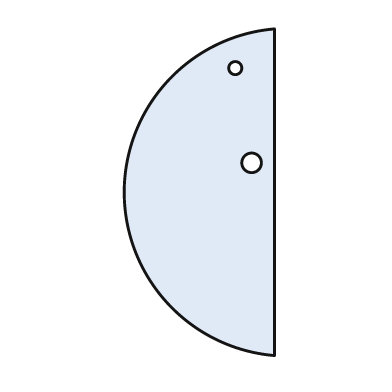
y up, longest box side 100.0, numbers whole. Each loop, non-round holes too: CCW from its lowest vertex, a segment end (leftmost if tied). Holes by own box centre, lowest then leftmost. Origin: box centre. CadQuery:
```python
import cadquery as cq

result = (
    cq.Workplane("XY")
    .moveTo(23.0, -50.0)
    .lineTo(23.0, 50.0)
    .threePointArc((-23.0, 0.0), (23.0, -50.0))
    .close()
    .moveTo(16.0, 9.0)
    .circle(3.0)
    .moveTo(11.0, 38.0)
    .circle(2.0)
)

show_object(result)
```